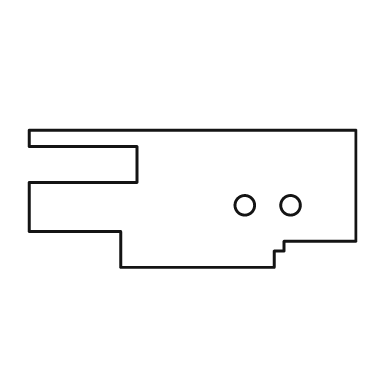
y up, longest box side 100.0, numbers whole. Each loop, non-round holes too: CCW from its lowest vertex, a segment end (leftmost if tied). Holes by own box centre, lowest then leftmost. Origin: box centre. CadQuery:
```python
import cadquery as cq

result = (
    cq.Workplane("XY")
    .moveTo(-22.0, -21.0)
    .lineTo(25.0, -21.0)
    .lineTo(25.0, -16.0)
    .lineTo(28.0, -16.0)
    .lineTo(28.0, -13.0)
    .lineTo(50.0, -13.0)
    .lineTo(50.0, 21.0)
    .lineTo(-50.0, 21.0)
    .lineTo(-50.0, 16.0)
    .lineTo(-17.0, 16.0)
    .lineTo(-17.0, 5.0)
    .lineTo(-50.0, 5.0)
    .lineTo(-50.0, -10.0)
    .lineTo(-22.0, -10.0)
    .close()
    .moveTo(16.0, -2.0)
    .circle(3.0)
    .moveTo(30.0, -2.0)
    .circle(3.0)
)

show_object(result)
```